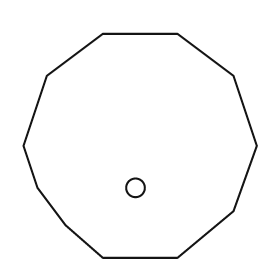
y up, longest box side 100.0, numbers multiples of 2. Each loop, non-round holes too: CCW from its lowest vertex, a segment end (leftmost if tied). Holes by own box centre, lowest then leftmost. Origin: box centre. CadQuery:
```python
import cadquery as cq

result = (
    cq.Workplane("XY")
    .moveTo(-16.0, -48.0)
    .lineTo(16.0, -48.0)
    .lineTo(40.0, -28.0)
    .lineTo(50.0, 0.0)
    .lineTo(40.0, 30.0)
    .lineTo(16.0, 48.0)
    .lineTo(-16.0, 48.0)
    .lineTo(-40.0, 30.0)
    .lineTo(-50.0, 0.0)
    .lineTo(-44.0, -18.0)
    .lineTo(-32.0, -34.0)
    .close()
    .moveTo(-2.0, -18.0)
    .circle(4.0)
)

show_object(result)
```